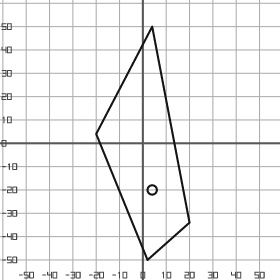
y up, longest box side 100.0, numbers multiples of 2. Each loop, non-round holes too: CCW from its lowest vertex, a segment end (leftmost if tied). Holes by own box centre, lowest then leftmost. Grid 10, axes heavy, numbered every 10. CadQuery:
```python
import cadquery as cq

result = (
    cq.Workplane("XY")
    .moveTo(2.0, -50.0)
    .lineTo(20.0, -34.0)
    .lineTo(4.0, 50.0)
    .lineTo(-20.0, 4.0)
    .close()
    .moveTo(4.0, -20.0)
    .circle(2.0)
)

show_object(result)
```